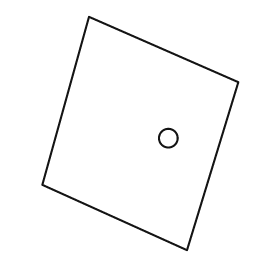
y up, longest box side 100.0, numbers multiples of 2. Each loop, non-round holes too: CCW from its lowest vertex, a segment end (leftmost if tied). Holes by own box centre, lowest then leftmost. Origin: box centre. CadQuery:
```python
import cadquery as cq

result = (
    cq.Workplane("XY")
    .moveTo(20.0, -50.0)
    .lineTo(42.0, 22.0)
    .lineTo(-22.0, 50.0)
    .lineTo(-42.0, -22.0)
    .close()
    .moveTo(12.0, -2.0)
    .circle(4.0)
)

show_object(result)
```